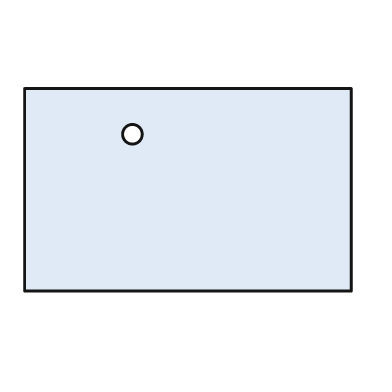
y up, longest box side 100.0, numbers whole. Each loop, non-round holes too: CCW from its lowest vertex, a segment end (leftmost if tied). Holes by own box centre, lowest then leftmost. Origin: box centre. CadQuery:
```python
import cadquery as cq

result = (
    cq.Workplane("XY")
    .moveTo(-50.0, -31.0)
    .lineTo(50.0, -31.0)
    .lineTo(50.0, 31.0)
    .lineTo(-50.0, 31.0)
    .close()
    .moveTo(-17.0, 17.0)
    .circle(3.0)
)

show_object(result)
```